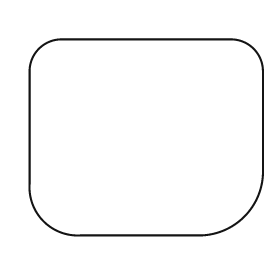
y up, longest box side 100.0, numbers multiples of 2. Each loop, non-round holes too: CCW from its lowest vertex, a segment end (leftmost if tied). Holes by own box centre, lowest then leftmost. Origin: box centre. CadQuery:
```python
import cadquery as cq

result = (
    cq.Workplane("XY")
    .moveTo(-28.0, -42.0)
    .lineTo(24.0, -42.0)
    .threePointArc((42.0, -34.0), (50.0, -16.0))
    .lineTo(50.0, 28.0)
    .threePointArc((46.0, 38.0), (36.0, 42.0))
    .lineTo(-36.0, 42.0)
    .threePointArc((-46.0, 38.0), (-50.0, 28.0))
    .lineTo(-50.0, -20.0)
    .threePointArc((-44.0, -36.0), (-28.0, -42.0))
    .close()
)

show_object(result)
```